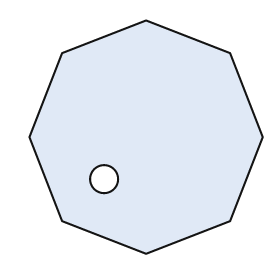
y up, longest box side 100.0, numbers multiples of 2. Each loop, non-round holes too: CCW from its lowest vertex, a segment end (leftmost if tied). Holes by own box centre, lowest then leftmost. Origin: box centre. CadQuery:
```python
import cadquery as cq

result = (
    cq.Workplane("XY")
    .moveTo(0.0, -50.0)
    .lineTo(36.0, -36.0)
    .lineTo(50.0, 0.0)
    .lineTo(36.0, 36.0)
    .lineTo(0.0, 50.0)
    .lineTo(-36.0, 36.0)
    .lineTo(-50.0, 0.0)
    .lineTo(-36.0, -36.0)
    .close()
    .moveTo(-18.0, -18.0)
    .circle(6.0)
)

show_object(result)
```